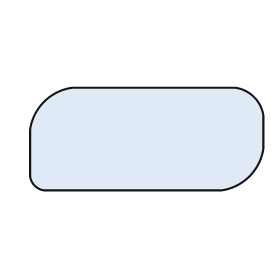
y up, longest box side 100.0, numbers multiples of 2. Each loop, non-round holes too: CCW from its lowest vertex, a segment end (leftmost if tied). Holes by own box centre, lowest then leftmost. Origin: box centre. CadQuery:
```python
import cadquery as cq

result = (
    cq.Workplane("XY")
    .moveTo(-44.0, -22.0)
    .lineTo(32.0, -22.0)
    .threePointArc((44.0, -16.0), (50.0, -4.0))
    .lineTo(50.0, 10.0)
    .threePointArc((46.0, 18.0), (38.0, 22.0))
    .lineTo(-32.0, 22.0)
    .threePointArc((-44.0, 16.0), (-50.0, 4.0))
    .lineTo(-50.0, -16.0)
    .threePointArc((-48.0, -20.0), (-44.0, -22.0))
    .close()
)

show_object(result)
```